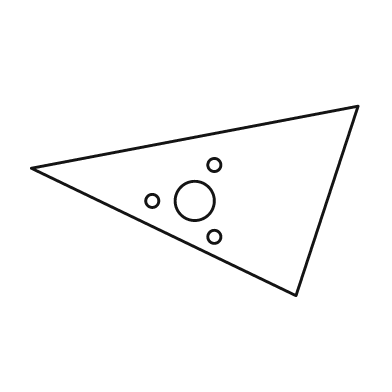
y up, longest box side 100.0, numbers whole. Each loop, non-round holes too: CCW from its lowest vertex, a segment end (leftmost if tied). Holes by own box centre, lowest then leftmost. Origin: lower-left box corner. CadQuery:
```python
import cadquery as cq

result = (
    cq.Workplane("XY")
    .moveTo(81.0, 0.0)
    .lineTo(100.0, 58.0)
    .lineTo(0.0, 39.0)
    .close()
    .moveTo(56.0, 18.0)
    .circle(2.0)
    .moveTo(37.0, 29.0)
    .circle(2.0)
    .moveTo(50.0, 29.0)
    .circle(6.0)
    .moveTo(56.0, 40.0)
    .circle(2.0)
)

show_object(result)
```